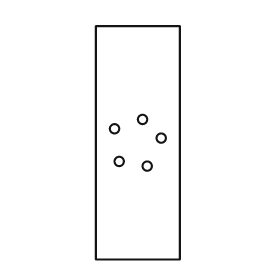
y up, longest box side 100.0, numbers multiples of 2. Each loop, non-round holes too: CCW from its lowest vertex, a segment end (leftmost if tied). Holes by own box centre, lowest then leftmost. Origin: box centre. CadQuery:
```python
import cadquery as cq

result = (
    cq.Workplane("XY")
    .moveTo(-18.0, -50.0)
    .lineTo(18.0, -50.0)
    .lineTo(18.0, 50.0)
    .lineTo(-18.0, 50.0)
    .close()
    .moveTo(4.0, -10.0)
    .circle(2.0)
    .moveTo(-8.0, -8.0)
    .circle(2.0)
    .moveTo(10.0, 2.0)
    .circle(2.0)
    .moveTo(-10.0, 6.0)
    .circle(2.0)
    .moveTo(2.0, 10.0)
    .circle(2.0)
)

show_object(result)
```